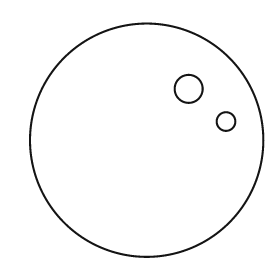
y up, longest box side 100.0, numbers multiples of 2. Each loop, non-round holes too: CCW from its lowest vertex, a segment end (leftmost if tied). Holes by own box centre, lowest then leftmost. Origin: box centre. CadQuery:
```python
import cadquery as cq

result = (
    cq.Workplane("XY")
    .moveTo(0.0, 0.0)
    .circle(50.0)
    .moveTo(34.0, 8.0)
    .circle(4.0)
    .moveTo(18.0, 22.0)
    .circle(6.0)
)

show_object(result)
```